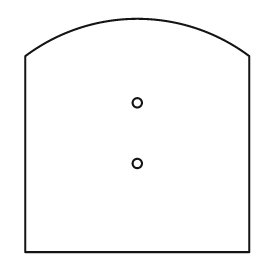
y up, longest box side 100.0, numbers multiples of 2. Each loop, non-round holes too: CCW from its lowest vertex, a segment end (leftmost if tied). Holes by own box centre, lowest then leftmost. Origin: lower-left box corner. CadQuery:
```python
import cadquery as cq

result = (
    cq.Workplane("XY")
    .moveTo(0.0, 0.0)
    .lineTo(96.0, 0.0)
    .lineTo(96.0, 84.0)
    .threePointArc((48.0, 100.0), (0.0, 84.0))
    .close()
    .moveTo(48.0, 38.0)
    .circle(2.0)
    .moveTo(48.0, 64.0)
    .circle(2.0)
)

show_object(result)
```